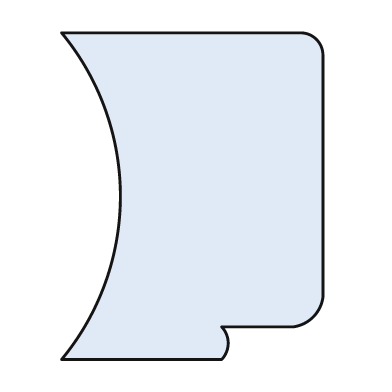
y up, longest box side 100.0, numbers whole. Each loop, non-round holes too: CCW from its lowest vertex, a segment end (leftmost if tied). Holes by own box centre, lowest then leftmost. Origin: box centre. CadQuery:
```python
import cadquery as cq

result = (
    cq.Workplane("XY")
    .moveTo(-40.0, -50.0)
    .lineTo(9.0, -50.0)
    .threePointArc((11.0, -45.0), (9.0, -40.0))
    .lineTo(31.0, -40.0)
    .threePointArc((37.0, -37.0), (40.0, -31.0))
    .lineTo(40.0, 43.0)
    .threePointArc((38.0, 48.0), (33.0, 50.0))
    .lineTo(-40.0, 50.0)
    .threePointArc((-22.0, 0.0), (-40.0, -50.0))
    .close()
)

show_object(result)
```